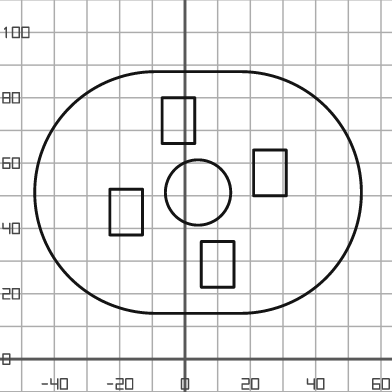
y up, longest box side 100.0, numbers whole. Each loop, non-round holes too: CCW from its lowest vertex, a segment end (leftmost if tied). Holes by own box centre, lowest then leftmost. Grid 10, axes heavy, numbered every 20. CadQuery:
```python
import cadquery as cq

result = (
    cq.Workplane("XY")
    .moveTo(-9.0, 14.0)
    .lineTo(17.0, 14.0)
    .threePointArc((54.0, 51.0), (17.0, 88.0))
    .lineTo(-9.0, 88.0)
    .threePointArc((-46.0, 51.0), (-9.0, 14.0))
    .close()
    .moveTo(5.0, 22.0)
    .lineTo(15.0, 22.0)
    .lineTo(15.0, 36.0)
    .lineTo(5.0, 36.0)
    .close()
    .moveTo(-23.0, 38.0)
    .lineTo(-13.0, 38.0)
    .lineTo(-13.0, 52.0)
    .lineTo(-23.0, 52.0)
    .close()
    .moveTo(4.0, 51.0)
    .circle(10.0)
    .moveTo(21.0, 50.0)
    .lineTo(31.0, 50.0)
    .lineTo(31.0, 64.0)
    .lineTo(21.0, 64.0)
    .close()
    .moveTo(-7.0, 66.0)
    .lineTo(3.0, 66.0)
    .lineTo(3.0, 80.0)
    .lineTo(-7.0, 80.0)
    .close()
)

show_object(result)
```